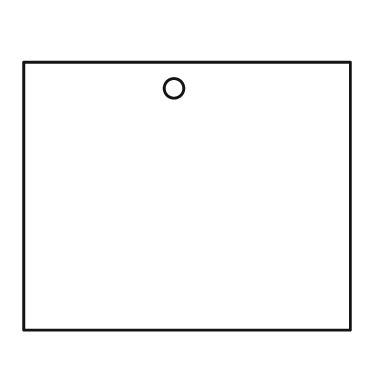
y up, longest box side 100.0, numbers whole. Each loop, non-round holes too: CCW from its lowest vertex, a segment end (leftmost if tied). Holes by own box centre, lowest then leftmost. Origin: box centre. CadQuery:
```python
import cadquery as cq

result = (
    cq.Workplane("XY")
    .moveTo(-50.0, -41.0)
    .lineTo(50.0, -41.0)
    .lineTo(50.0, 41.0)
    .lineTo(-50.0, 41.0)
    .close()
    .moveTo(-4.0, 33.0)
    .circle(3.0)
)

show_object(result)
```